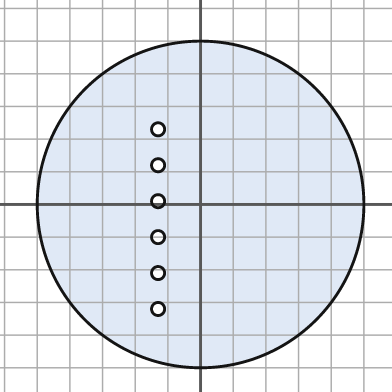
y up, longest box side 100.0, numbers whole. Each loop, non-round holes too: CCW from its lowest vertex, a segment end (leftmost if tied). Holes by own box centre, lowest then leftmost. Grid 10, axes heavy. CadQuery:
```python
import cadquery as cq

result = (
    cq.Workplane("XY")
    .moveTo(0.0, 0.0)
    .circle(50.0)
    .moveTo(-13.0, -32.0)
    .circle(2.0)
    .moveTo(-13.0, -21.0)
    .circle(2.0)
    .moveTo(-13.0, -10.0)
    .circle(2.0)
    .moveTo(-13.0, 1.0)
    .circle(2.0)
    .moveTo(-13.0, 12.0)
    .circle(2.0)
    .moveTo(-13.0, 23.0)
    .circle(2.0)
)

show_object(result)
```